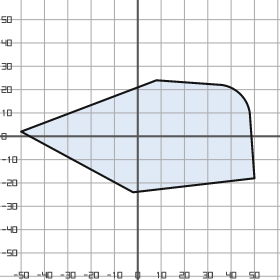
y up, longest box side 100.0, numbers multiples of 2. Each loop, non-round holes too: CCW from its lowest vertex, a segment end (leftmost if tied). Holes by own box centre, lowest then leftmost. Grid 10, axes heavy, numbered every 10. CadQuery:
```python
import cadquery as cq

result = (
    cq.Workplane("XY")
    .moveTo(-2.0, -24.0)
    .lineTo(50.0, -18.0)
    .lineTo(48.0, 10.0)
    .threePointArc((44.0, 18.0), (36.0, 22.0))
    .lineTo(8.0, 24.0)
    .lineTo(-50.0, 2.0)
    .close()
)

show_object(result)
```